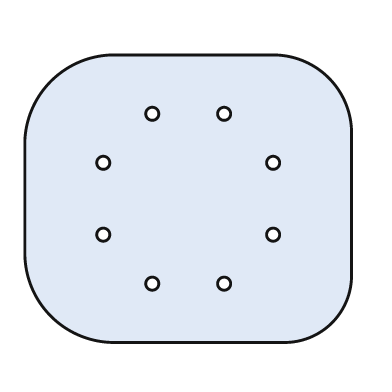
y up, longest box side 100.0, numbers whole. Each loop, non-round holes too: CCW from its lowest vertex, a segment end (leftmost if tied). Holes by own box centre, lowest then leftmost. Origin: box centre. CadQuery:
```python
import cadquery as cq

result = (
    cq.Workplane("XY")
    .moveTo(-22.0, -44.0)
    .lineTo(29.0, -44.0)
    .threePointArc((44.0, -38.0), (50.0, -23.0))
    .lineTo(50.0, 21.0)
    .threePointArc((43.0, 37.0), (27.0, 44.0))
    .lineTo(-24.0, 44.0)
    .threePointArc((-42.0, 36.0), (-50.0, 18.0))
    .lineTo(-50.0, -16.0)
    .threePointArc((-42.0, -36.0), (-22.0, -44.0))
    .close()
    .moveTo(-11.0, -26.0)
    .circle(2.0)
    .moveTo(11.0, -26.0)
    .circle(2.0)
    .moveTo(-26.0, -11.0)
    .circle(2.0)
    .moveTo(26.0, -11.0)
    .circle(2.0)
    .moveTo(-26.0, 11.0)
    .circle(2.0)
    .moveTo(26.0, 11.0)
    .circle(2.0)
    .moveTo(-11.0, 26.0)
    .circle(2.0)
    .moveTo(11.0, 26.0)
    .circle(2.0)
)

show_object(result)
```